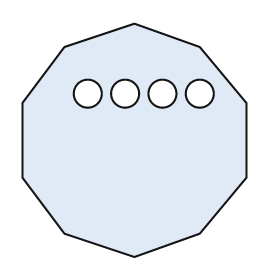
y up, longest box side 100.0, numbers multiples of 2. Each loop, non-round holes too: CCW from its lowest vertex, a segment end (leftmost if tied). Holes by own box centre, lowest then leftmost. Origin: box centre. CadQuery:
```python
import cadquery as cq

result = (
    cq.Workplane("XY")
    .moveTo(0.0, -50.0)
    .lineTo(28.0, -40.0)
    .lineTo(48.0, -16.0)
    .lineTo(48.0, 16.0)
    .lineTo(28.0, 40.0)
    .lineTo(0.0, 50.0)
    .lineTo(-30.0, 40.0)
    .lineTo(-48.0, 16.0)
    .lineTo(-48.0, -16.0)
    .lineTo(-30.0, -40.0)
    .close()
    .moveTo(-20.0, 20.0)
    .circle(6.0)
    .moveTo(-4.0, 20.0)
    .circle(6.0)
    .moveTo(12.0, 20.0)
    .circle(6.0)
    .moveTo(28.0, 20.0)
    .circle(6.0)
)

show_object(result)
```